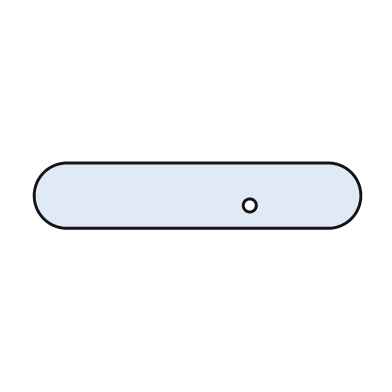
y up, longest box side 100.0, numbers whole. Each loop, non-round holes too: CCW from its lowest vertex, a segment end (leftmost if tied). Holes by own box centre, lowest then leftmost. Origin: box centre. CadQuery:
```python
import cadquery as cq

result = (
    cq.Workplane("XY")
    .moveTo(-40.0, -10.0)
    .lineTo(40.0, -10.0)
    .threePointArc((50.0, 0.0), (40.0, 10.0))
    .lineTo(-40.0, 10.0)
    .threePointArc((-50.0, 0.0), (-40.0, -10.0))
    .close()
    .moveTo(16.0, -3.0)
    .circle(2.0)
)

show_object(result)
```